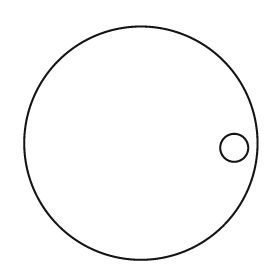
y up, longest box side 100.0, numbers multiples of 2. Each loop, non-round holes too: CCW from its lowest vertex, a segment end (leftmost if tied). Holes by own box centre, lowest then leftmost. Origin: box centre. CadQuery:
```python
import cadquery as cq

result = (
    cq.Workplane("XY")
    .moveTo(0.0, 0.0)
    .circle(50.0)
    .moveTo(40.0, -2.0)
    .circle(6.0)
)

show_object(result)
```